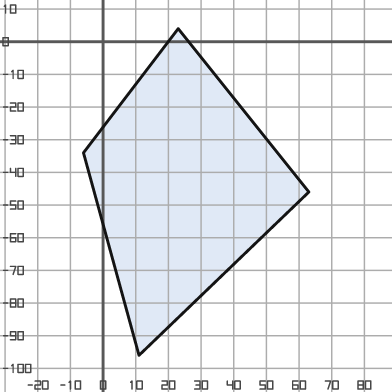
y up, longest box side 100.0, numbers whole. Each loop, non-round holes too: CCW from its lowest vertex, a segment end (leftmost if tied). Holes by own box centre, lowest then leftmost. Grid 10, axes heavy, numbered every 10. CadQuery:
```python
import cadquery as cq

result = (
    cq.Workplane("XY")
    .moveTo(11.0, -96.0)
    .lineTo(63.0, -46.0)
    .lineTo(23.0, 4.0)
    .lineTo(-6.0, -34.0)
    .close()
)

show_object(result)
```